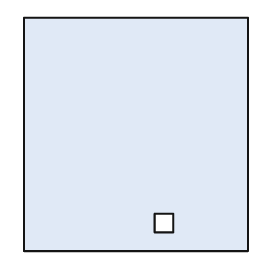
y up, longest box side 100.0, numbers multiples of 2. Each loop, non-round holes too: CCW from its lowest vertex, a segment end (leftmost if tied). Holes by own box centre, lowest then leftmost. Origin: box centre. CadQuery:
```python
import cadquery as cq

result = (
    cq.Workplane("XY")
    .moveTo(-48.0, -50.0)
    .lineTo(48.0, -50.0)
    .lineTo(48.0, 50.0)
    .lineTo(-48.0, 50.0)
    .close()
    .moveTo(8.0, -42.0)
    .lineTo(16.0, -42.0)
    .lineTo(16.0, -34.0)
    .lineTo(8.0, -34.0)
    .close()
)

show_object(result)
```